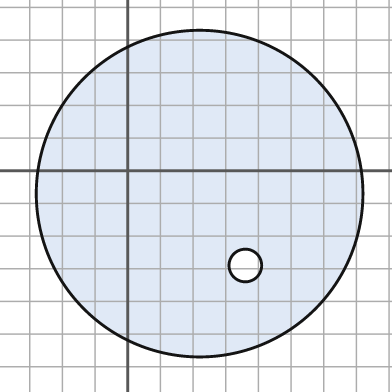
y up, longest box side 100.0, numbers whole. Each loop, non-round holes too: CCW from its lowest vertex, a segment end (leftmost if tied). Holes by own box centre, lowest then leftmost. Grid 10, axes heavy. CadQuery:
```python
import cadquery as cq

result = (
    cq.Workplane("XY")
    .moveTo(22.0, -7.0)
    .circle(50.0)
    .moveTo(36.0, -29.0)
    .circle(5.0)
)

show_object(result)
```